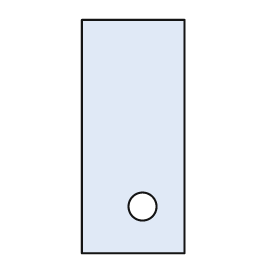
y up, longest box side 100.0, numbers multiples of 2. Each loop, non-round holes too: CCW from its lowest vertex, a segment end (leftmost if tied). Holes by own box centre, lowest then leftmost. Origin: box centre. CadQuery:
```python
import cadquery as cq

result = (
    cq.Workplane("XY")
    .moveTo(-22.0, -50.0)
    .lineTo(22.0, -50.0)
    .lineTo(22.0, 50.0)
    .lineTo(-22.0, 50.0)
    .close()
    .moveTo(4.0, -30.0)
    .circle(6.0)
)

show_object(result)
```